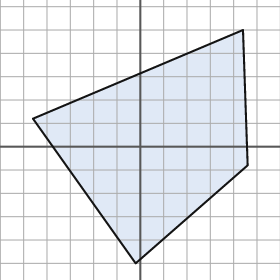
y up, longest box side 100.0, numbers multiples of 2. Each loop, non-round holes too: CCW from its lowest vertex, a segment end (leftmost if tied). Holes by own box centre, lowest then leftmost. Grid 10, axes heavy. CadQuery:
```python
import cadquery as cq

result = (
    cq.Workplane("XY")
    .moveTo(-2.0, -50.0)
    .lineTo(46.0, -8.0)
    .lineTo(44.0, 50.0)
    .lineTo(-46.0, 12.0)
    .close()
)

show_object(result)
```